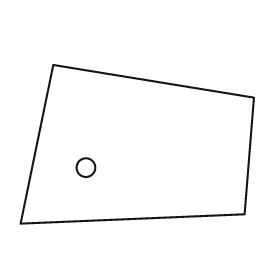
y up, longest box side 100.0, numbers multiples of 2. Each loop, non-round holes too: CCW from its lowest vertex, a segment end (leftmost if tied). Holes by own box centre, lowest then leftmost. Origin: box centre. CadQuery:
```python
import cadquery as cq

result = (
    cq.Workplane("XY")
    .moveTo(-50.0, -34.0)
    .lineTo(46.0, -30.0)
    .lineTo(50.0, 20.0)
    .lineTo(-36.0, 34.0)
    .close()
    .moveTo(-22.0, -10.0)
    .circle(4.0)
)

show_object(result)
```